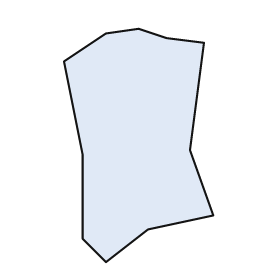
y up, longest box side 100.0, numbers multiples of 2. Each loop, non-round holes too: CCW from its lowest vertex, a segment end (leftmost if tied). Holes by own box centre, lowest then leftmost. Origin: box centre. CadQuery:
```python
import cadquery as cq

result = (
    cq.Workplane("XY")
    .moveTo(-14.0, -50.0)
    .lineTo(4.0, -36.0)
    .lineTo(32.0, -30.0)
    .lineTo(22.0, -2.0)
    .lineTo(28.0, 44.0)
    .lineTo(12.0, 46.0)
    .lineTo(0.0, 50.0)
    .lineTo(-14.0, 48.0)
    .lineTo(-32.0, 36.0)
    .lineTo(-24.0, -4.0)
    .lineTo(-24.0, -40.0)
    .close()
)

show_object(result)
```